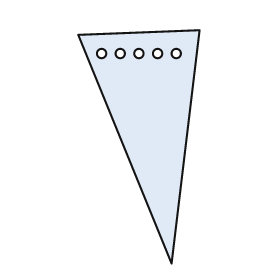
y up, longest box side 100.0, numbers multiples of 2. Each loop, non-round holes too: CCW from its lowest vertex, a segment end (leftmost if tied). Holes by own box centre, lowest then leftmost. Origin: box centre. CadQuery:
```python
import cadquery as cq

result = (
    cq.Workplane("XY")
    .moveTo(14.0, -50.0)
    .lineTo(26.0, 50.0)
    .lineTo(-26.0, 48.0)
    .close()
    .moveTo(-16.0, 40.0)
    .circle(2.0)
    .moveTo(-8.0, 40.0)
    .circle(2.0)
    .moveTo(0.0, 40.0)
    .circle(2.0)
    .moveTo(8.0, 40.0)
    .circle(2.0)
    .moveTo(16.0, 40.0)
    .circle(2.0)
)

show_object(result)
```